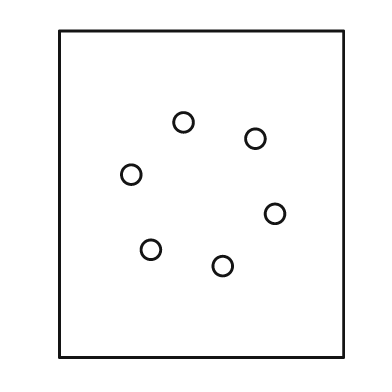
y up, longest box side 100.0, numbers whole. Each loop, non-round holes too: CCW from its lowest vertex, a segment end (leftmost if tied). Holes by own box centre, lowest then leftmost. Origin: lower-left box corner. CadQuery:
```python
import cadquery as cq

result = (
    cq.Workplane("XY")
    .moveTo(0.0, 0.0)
    .lineTo(87.0, 0.0)
    .lineTo(87.0, 100.0)
    .lineTo(0.0, 100.0)
    .close()
    .moveTo(50.0, 28.0)
    .circle(3.0)
    .moveTo(28.0, 33.0)
    .circle(3.0)
    .moveTo(66.0, 44.0)
    .circle(3.0)
    .moveTo(22.0, 56.0)
    .circle(3.0)
    .moveTo(60.0, 67.0)
    .circle(3.0)
    .moveTo(38.0, 72.0)
    .circle(3.0)
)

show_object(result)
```